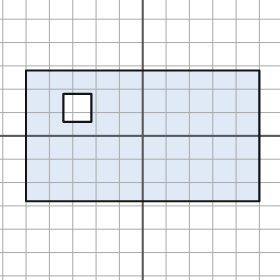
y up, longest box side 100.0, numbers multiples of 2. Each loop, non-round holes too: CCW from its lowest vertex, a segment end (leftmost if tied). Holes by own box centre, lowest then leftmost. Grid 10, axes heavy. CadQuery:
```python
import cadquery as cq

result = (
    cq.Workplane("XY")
    .moveTo(-50.0, -28.0)
    .lineTo(50.0, -28.0)
    .lineTo(50.0, 28.0)
    .lineTo(-50.0, 28.0)
    .close()
    .moveTo(-34.0, 6.0)
    .lineTo(-22.0, 6.0)
    .lineTo(-22.0, 18.0)
    .lineTo(-34.0, 18.0)
    .close()
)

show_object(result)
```